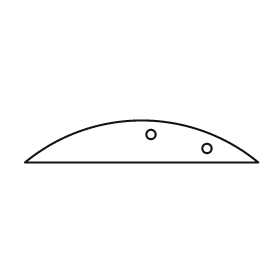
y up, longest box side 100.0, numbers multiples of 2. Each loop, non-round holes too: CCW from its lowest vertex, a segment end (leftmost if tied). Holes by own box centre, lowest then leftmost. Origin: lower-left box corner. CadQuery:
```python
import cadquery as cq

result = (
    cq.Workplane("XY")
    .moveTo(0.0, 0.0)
    .lineTo(100.0, 0.0)
    .threePointArc((50.0, 18.0), (0.0, 0.0))
    .close()
    .moveTo(78.0, 6.0)
    .circle(2.0)
    .moveTo(54.0, 12.0)
    .circle(2.0)
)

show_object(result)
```